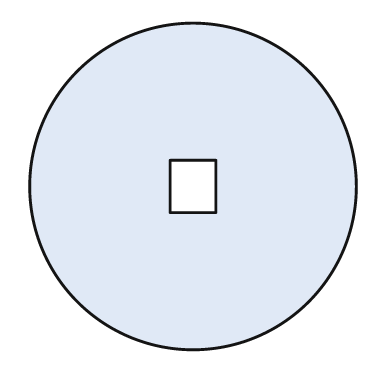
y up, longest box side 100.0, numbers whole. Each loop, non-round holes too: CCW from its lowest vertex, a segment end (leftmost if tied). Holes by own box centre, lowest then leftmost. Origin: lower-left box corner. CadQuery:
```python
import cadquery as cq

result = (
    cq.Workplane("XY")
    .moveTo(50.0, 50.0)
    .circle(50.0)
    .moveTo(43.0, 42.0)
    .lineTo(57.0, 42.0)
    .lineTo(57.0, 58.0)
    .lineTo(43.0, 58.0)
    .close()
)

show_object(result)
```